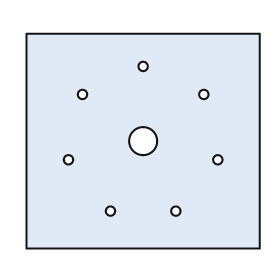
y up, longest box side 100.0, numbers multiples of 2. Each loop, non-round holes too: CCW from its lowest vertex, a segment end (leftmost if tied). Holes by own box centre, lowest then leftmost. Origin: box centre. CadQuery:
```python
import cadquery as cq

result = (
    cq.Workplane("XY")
    .moveTo(-50.0, -46.0)
    .lineTo(50.0, -46.0)
    .lineTo(50.0, 46.0)
    .lineTo(-50.0, 46.0)
    .close()
    .moveTo(-14.0, -30.0)
    .circle(2.0)
    .moveTo(14.0, -30.0)
    .circle(2.0)
    .moveTo(-32.0, -8.0)
    .circle(2.0)
    .moveTo(32.0, -8.0)
    .circle(2.0)
    .moveTo(0.0, 0.0)
    .circle(6.0)
    .moveTo(-26.0, 20.0)
    .circle(2.0)
    .moveTo(26.0, 20.0)
    .circle(2.0)
    .moveTo(0.0, 32.0)
    .circle(2.0)
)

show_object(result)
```